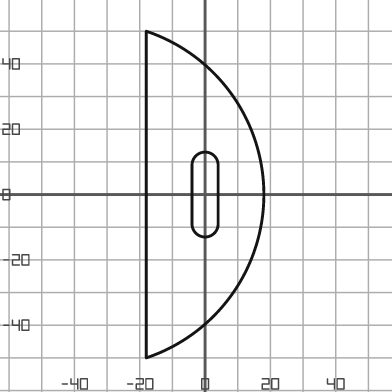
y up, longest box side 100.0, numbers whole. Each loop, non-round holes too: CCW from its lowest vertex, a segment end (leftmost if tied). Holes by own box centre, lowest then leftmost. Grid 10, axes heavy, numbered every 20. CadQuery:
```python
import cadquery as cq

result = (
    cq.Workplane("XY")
    .moveTo(-18.0, -50.0)
    .threePointArc((18.0, 0.0), (-18.0, 50.0))
    .close()
    .moveTo(-4.0, -9.0)
    .threePointArc((0.0, -13.0), (4.0, -9.0))
    .lineTo(4.0, 9.0)
    .threePointArc((0.0, 13.0), (-4.0, 9.0))
    .close()
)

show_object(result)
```